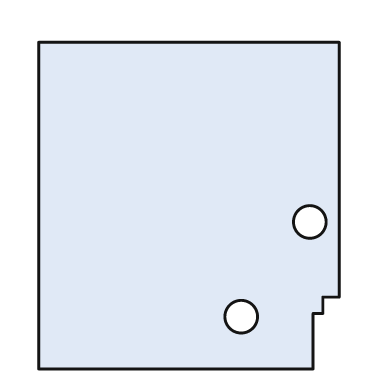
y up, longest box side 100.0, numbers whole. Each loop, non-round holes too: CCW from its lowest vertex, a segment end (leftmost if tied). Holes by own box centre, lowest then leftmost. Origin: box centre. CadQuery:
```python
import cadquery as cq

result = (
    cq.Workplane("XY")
    .moveTo(-46.0, -50.0)
    .lineTo(38.0, -50.0)
    .lineTo(38.0, -33.0)
    .lineTo(41.0, -33.0)
    .lineTo(41.0, -28.0)
    .lineTo(46.0, -28.0)
    .lineTo(46.0, 50.0)
    .lineTo(-46.0, 50.0)
    .close()
    .moveTo(16.0, -34.0)
    .circle(5.0)
    .moveTo(37.0, -5.0)
    .circle(5.0)
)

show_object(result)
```